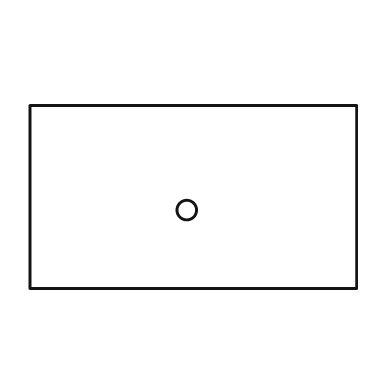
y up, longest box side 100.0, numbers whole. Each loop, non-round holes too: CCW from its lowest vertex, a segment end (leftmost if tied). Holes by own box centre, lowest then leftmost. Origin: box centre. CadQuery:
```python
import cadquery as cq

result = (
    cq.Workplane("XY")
    .moveTo(-50.0, -28.0)
    .lineTo(50.0, -28.0)
    .lineTo(50.0, 28.0)
    .lineTo(-50.0, 28.0)
    .close()
    .moveTo(-2.0, -4.0)
    .circle(3.0)
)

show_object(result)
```